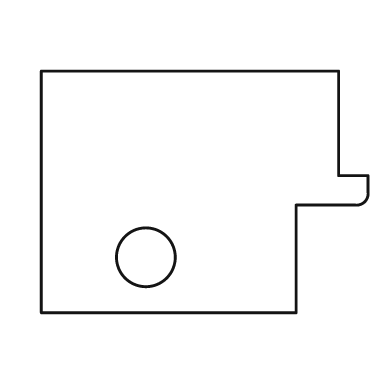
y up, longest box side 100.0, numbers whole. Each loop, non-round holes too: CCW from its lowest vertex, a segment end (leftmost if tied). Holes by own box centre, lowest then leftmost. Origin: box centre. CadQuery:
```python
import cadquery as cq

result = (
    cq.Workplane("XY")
    .moveTo(-50.0, -37.0)
    .lineTo(28.0, -37.0)
    .lineTo(28.0, -4.0)
    .lineTo(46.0, -4.0)
    .threePointArc((49.0, -3.0), (50.0, 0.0))
    .lineTo(50.0, 5.0)
    .lineTo(41.0, 5.0)
    .lineTo(41.0, 37.0)
    .lineTo(-50.0, 37.0)
    .close()
    .moveTo(-18.0, -20.0)
    .circle(9.0)
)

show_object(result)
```